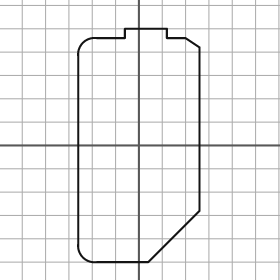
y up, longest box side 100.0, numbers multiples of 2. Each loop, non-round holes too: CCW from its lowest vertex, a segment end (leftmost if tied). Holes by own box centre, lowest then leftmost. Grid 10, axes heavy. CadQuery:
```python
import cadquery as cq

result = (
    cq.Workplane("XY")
    .moveTo(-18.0, -50.0)
    .lineTo(4.0, -50.0)
    .lineTo(26.0, -28.0)
    .lineTo(26.0, 42.0)
    .lineTo(20.0, 46.0)
    .lineTo(12.0, 46.0)
    .lineTo(12.0, 50.0)
    .lineTo(-6.0, 50.0)
    .lineTo(-6.0, 46.0)
    .lineTo(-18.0, 46.0)
    .threePointArc((-24.0, 44.0), (-26.0, 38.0))
    .lineTo(-26.0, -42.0)
    .threePointArc((-24.0, -48.0), (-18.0, -50.0))
    .close()
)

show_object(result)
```